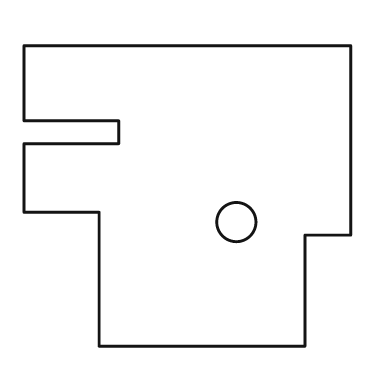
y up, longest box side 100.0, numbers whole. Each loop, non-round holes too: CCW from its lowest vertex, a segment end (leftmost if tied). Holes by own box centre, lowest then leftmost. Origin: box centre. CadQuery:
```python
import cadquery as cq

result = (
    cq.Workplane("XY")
    .moveTo(-27.0, -46.0)
    .lineTo(36.0, -46.0)
    .lineTo(36.0, -12.0)
    .lineTo(50.0, -12.0)
    .lineTo(50.0, 46.0)
    .lineTo(-50.0, 46.0)
    .lineTo(-50.0, 23.0)
    .lineTo(-21.0, 23.0)
    .lineTo(-21.0, 16.0)
    .lineTo(-50.0, 16.0)
    .lineTo(-50.0, -5.0)
    .lineTo(-27.0, -5.0)
    .close()
    .moveTo(15.0, -8.0)
    .circle(6.0)
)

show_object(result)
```